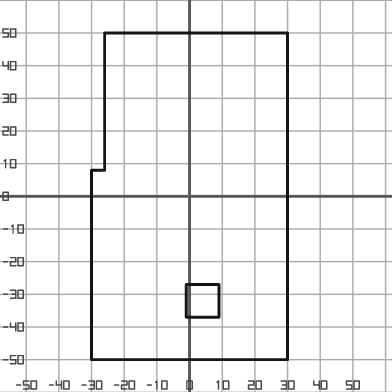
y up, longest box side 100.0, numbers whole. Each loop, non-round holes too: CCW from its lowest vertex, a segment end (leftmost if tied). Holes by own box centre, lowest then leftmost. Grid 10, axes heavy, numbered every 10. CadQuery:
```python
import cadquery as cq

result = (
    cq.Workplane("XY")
    .moveTo(-30.0, -50.0)
    .lineTo(30.0, -50.0)
    .lineTo(30.0, 50.0)
    .lineTo(-26.0, 50.0)
    .lineTo(-26.0, 8.0)
    .lineTo(-30.0, 8.0)
    .close()
    .moveTo(-1.0, -37.0)
    .lineTo(9.0, -37.0)
    .lineTo(9.0, -27.0)
    .lineTo(-1.0, -27.0)
    .close()
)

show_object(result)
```